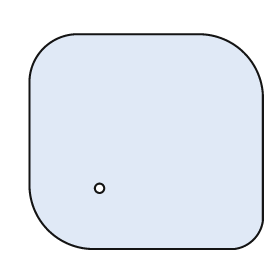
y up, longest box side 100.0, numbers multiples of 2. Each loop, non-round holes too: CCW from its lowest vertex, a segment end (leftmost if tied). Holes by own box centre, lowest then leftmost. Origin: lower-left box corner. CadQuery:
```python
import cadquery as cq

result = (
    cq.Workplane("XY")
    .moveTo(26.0, 0.0)
    .lineTo(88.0, 0.0)
    .threePointArc((96.0, 4.0), (100.0, 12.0))
    .lineTo(100.0, 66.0)
    .threePointArc((92.0, 84.0), (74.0, 92.0))
    .lineTo(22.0, 92.0)
    .threePointArc((6.0, 86.0), (0.0, 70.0))
    .lineTo(0.0, 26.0)
    .threePointArc((8.0, 8.0), (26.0, 0.0))
    .close()
    .moveTo(30.0, 26.0)
    .circle(2.0)
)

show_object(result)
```